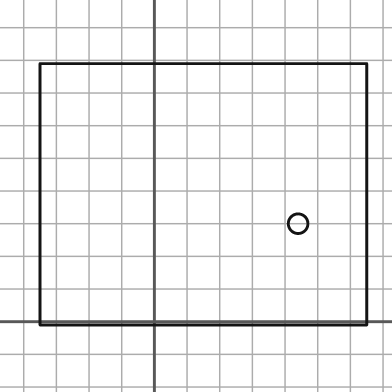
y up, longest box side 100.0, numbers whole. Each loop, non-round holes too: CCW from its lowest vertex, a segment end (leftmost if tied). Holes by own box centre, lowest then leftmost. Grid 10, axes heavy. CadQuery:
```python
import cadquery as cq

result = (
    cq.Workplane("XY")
    .moveTo(-35.0, -1.0)
    .lineTo(65.0, -1.0)
    .lineTo(65.0, 79.0)
    .lineTo(-35.0, 79.0)
    .close()
    .moveTo(44.0, 30.0)
    .circle(3.0)
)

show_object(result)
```